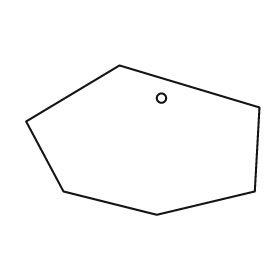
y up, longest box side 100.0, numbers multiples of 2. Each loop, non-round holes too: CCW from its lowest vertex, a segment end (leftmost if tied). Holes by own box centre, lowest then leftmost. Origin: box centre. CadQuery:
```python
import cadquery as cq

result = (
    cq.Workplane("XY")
    .moveTo(6.0, -32.0)
    .lineTo(48.0, -22.0)
    .lineTo(50.0, 14.0)
    .lineTo(-10.0, 32.0)
    .lineTo(-50.0, 8.0)
    .lineTo(-34.0, -22.0)
    .close()
    .moveTo(8.0, 18.0)
    .circle(2.0)
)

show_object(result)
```